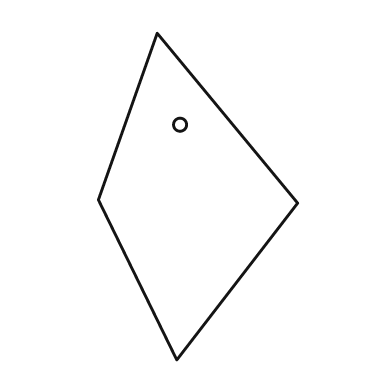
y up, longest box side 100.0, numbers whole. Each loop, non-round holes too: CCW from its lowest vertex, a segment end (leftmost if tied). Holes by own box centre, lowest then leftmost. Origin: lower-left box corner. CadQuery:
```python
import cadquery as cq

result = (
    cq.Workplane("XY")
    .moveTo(24.0, 0.0)
    .lineTo(61.0, 48.0)
    .lineTo(18.0, 100.0)
    .lineTo(0.0, 49.0)
    .close()
    .moveTo(25.0, 72.0)
    .circle(2.0)
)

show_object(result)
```